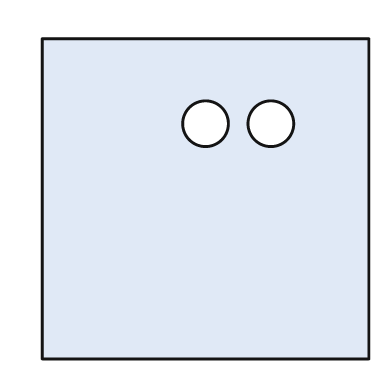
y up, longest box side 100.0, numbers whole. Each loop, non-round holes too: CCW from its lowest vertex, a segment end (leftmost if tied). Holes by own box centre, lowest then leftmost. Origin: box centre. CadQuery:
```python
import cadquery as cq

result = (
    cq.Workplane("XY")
    .moveTo(-50.0, -49.0)
    .lineTo(50.0, -49.0)
    .lineTo(50.0, 49.0)
    .lineTo(-50.0, 49.0)
    .close()
    .moveTo(0.0, 23.0)
    .circle(7.0)
    .moveTo(20.0, 23.0)
    .circle(7.0)
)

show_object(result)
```